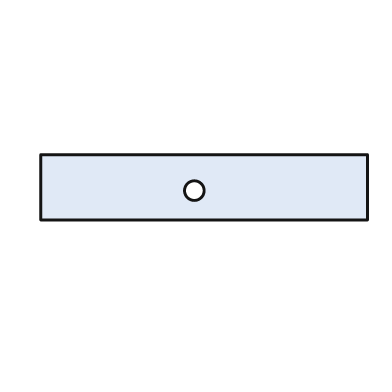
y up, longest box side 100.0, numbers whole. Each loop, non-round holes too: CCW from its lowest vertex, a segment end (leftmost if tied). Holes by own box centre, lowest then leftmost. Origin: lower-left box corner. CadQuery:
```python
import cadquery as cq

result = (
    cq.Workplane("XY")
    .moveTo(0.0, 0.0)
    .lineTo(100.0, 0.0)
    .lineTo(100.0, 20.0)
    .lineTo(0.0, 20.0)
    .close()
    .moveTo(47.0, 9.0)
    .circle(3.0)
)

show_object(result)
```